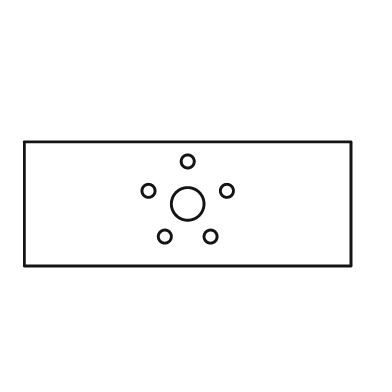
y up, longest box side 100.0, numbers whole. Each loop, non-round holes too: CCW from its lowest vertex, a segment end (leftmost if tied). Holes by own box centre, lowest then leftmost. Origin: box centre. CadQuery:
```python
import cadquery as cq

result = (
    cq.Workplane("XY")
    .moveTo(-50.0, -19.0)
    .lineTo(50.0, -19.0)
    .lineTo(50.0, 19.0)
    .lineTo(-50.0, 19.0)
    .close()
    .moveTo(-7.0, -10.0)
    .circle(2.0)
    .moveTo(7.0, -10.0)
    .circle(2.0)
    .moveTo(0.0, 0.0)
    .circle(5.0)
    .moveTo(-12.0, 4.0)
    .circle(2.0)
    .moveTo(12.0, 4.0)
    .circle(2.0)
    .moveTo(0.0, 13.0)
    .circle(2.0)
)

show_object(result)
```